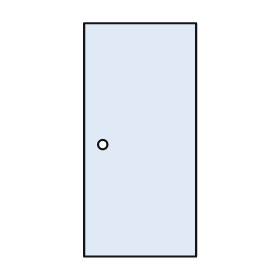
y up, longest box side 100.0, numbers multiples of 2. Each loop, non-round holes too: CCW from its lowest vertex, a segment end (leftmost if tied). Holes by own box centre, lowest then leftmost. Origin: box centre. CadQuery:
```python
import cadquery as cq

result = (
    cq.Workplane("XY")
    .moveTo(-24.0, -50.0)
    .lineTo(24.0, -50.0)
    .lineTo(24.0, 50.0)
    .lineTo(-24.0, 50.0)
    .close()
    .moveTo(-16.0, -2.0)
    .circle(2.0)
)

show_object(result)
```